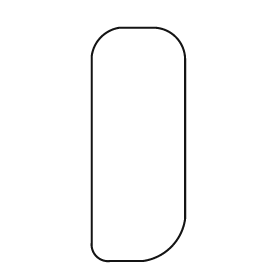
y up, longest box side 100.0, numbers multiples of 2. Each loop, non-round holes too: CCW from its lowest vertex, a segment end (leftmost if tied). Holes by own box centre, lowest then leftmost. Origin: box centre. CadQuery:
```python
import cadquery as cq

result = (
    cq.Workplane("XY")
    .moveTo(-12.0, -50.0)
    .lineTo(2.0, -50.0)
    .threePointArc((14.0, -44.0), (20.0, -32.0))
    .lineTo(20.0, 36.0)
    .threePointArc((16.0, 46.0), (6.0, 50.0))
    .lineTo(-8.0, 50.0)
    .threePointArc((-16.0, 46.0), (-20.0, 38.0))
    .lineTo(-20.0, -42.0)
    .threePointArc((-18.0, -48.0), (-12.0, -50.0))
    .close()
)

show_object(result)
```